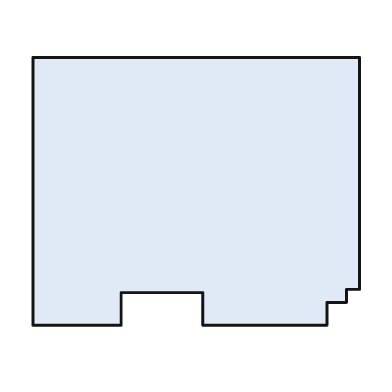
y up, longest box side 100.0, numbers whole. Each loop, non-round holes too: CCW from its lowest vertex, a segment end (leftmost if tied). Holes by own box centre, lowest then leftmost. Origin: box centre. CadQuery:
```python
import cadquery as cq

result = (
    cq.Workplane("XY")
    .moveTo(-50.0, -41.0)
    .lineTo(-23.0, -41.0)
    .lineTo(-23.0, -31.0)
    .lineTo(2.0, -31.0)
    .lineTo(2.0, -41.0)
    .lineTo(40.0, -41.0)
    .lineTo(40.0, -34.0)
    .lineTo(46.0, -34.0)
    .lineTo(46.0, -30.0)
    .lineTo(50.0, -30.0)
    .lineTo(50.0, 41.0)
    .lineTo(-50.0, 41.0)
    .close()
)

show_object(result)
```